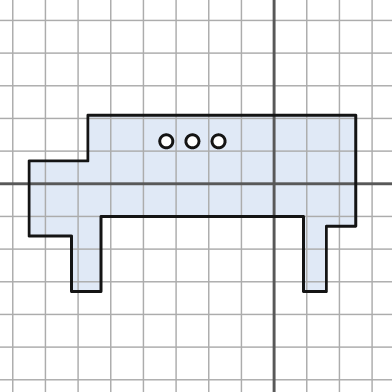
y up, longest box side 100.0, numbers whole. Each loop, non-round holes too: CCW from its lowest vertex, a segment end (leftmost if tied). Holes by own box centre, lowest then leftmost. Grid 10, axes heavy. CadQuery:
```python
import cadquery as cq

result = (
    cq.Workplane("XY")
    .moveTo(-62.0, -33.0)
    .lineTo(-53.0, -33.0)
    .lineTo(-53.0, -10.0)
    .lineTo(9.0, -10.0)
    .lineTo(9.0, -33.0)
    .lineTo(16.0, -33.0)
    .lineTo(16.0, -13.0)
    .lineTo(25.0, -13.0)
    .lineTo(25.0, 21.0)
    .lineTo(-57.0, 21.0)
    .lineTo(-57.0, 7.0)
    .lineTo(-75.0, 7.0)
    .lineTo(-75.0, -16.0)
    .lineTo(-62.0, -16.0)
    .close()
    .moveTo(-33.0, 13.0)
    .circle(2.0)
    .moveTo(-25.0, 13.0)
    .circle(2.0)
    .moveTo(-17.0, 13.0)
    .circle(2.0)
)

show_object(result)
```